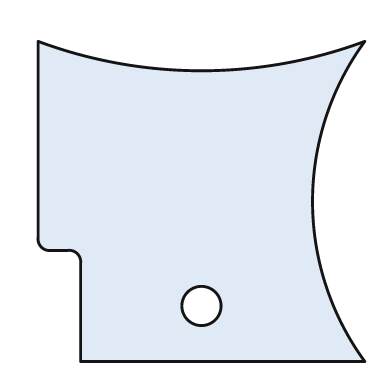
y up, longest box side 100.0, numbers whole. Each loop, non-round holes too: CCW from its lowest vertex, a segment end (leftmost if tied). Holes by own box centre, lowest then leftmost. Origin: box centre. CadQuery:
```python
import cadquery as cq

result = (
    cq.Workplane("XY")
    .moveTo(-37.0, -49.0)
    .lineTo(50.0, -49.0)
    .threePointArc((34.0, 0.0), (50.0, 49.0))
    .threePointArc((0.0, 40.0), (-50.0, 49.0))
    .lineTo(-50.0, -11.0)
    .threePointArc((-49.0, -14.0), (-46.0, -15.0))
    .lineTo(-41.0, -15.0)
    .threePointArc((-38.0, -16.0), (-37.0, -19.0))
    .close()
    .moveTo(0.0, -32.0)
    .circle(6.0)
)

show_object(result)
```